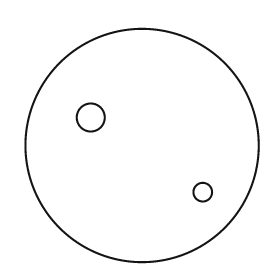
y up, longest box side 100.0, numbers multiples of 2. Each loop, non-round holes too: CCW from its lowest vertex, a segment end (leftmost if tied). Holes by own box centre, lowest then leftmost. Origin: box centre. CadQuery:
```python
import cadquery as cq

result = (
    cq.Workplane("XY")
    .moveTo(0.0, 0.0)
    .circle(50.0)
    .moveTo(26.0, -20.0)
    .circle(4.0)
    .moveTo(-22.0, 12.0)
    .circle(6.0)
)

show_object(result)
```